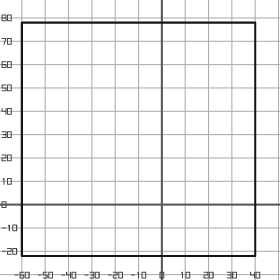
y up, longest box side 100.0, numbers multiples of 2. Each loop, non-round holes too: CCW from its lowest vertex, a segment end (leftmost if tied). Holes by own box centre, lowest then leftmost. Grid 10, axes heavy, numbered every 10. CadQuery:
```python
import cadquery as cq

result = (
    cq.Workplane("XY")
    .moveTo(-60.0, -22.0)
    .lineTo(40.0, -22.0)
    .lineTo(40.0, 78.0)
    .lineTo(-60.0, 78.0)
    .close()
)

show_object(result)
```